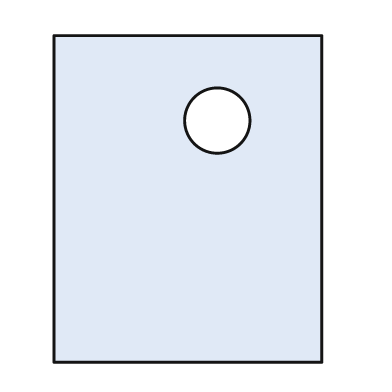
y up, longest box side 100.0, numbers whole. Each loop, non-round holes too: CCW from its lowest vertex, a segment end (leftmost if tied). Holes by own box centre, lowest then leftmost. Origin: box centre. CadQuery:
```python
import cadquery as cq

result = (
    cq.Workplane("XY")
    .moveTo(-41.0, -50.0)
    .lineTo(41.0, -50.0)
    .lineTo(41.0, 50.0)
    .lineTo(-41.0, 50.0)
    .close()
    .moveTo(9.0, 24.0)
    .circle(10.0)
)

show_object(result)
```